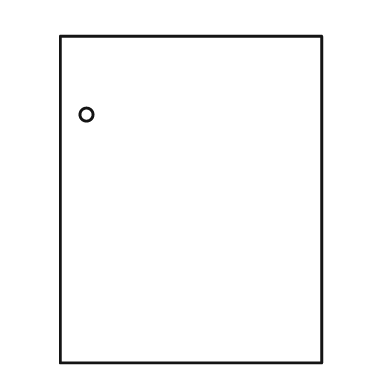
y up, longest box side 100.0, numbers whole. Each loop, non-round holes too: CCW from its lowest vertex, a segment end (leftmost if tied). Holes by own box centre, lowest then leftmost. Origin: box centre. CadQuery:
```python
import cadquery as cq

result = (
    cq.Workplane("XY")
    .moveTo(-40.0, -50.0)
    .lineTo(40.0, -50.0)
    .lineTo(40.0, 50.0)
    .lineTo(-40.0, 50.0)
    .close()
    .moveTo(-32.0, 26.0)
    .circle(2.0)
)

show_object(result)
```